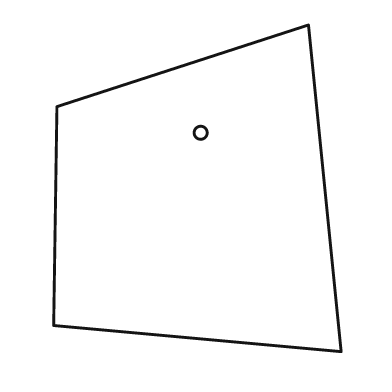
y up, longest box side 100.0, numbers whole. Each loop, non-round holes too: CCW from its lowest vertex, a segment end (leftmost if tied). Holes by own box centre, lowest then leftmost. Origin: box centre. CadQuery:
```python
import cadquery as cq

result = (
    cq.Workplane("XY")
    .moveTo(44.0, -50.0)
    .lineTo(34.0, 50.0)
    .lineTo(-43.0, 25.0)
    .lineTo(-44.0, -42.0)
    .close()
    .moveTo(1.0, 17.0)
    .circle(2.0)
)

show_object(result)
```